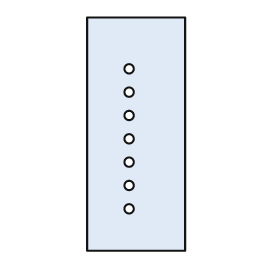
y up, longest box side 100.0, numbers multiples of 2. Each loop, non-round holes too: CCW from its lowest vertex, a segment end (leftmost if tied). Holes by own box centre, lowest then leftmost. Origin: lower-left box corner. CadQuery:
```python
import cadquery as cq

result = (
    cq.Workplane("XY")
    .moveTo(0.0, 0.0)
    .lineTo(42.0, 0.0)
    .lineTo(42.0, 100.0)
    .lineTo(0.0, 100.0)
    .close()
    .moveTo(18.0, 18.0)
    .circle(2.0)
    .moveTo(18.0, 28.0)
    .circle(2.0)
    .moveTo(18.0, 38.0)
    .circle(2.0)
    .moveTo(18.0, 48.0)
    .circle(2.0)
    .moveTo(18.0, 58.0)
    .circle(2.0)
    .moveTo(18.0, 68.0)
    .circle(2.0)
    .moveTo(18.0, 78.0)
    .circle(2.0)
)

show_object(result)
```